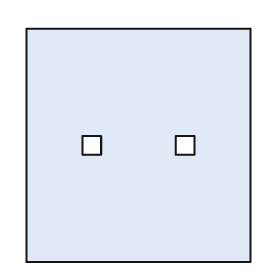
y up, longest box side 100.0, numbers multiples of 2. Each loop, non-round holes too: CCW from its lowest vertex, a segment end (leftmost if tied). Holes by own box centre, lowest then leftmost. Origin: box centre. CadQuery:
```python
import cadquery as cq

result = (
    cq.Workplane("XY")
    .moveTo(-48.0, -50.0)
    .lineTo(48.0, -50.0)
    .lineTo(48.0, 50.0)
    .lineTo(-48.0, 50.0)
    .close()
    .moveTo(-24.0, -4.0)
    .lineTo(-16.0, -4.0)
    .lineTo(-16.0, 4.0)
    .lineTo(-24.0, 4.0)
    .close()
    .moveTo(16.0, -4.0)
    .lineTo(24.0, -4.0)
    .lineTo(24.0, 4.0)
    .lineTo(16.0, 4.0)
    .close()
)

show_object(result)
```